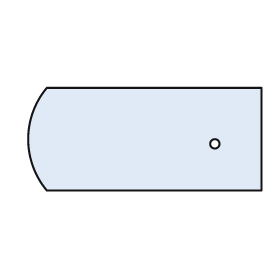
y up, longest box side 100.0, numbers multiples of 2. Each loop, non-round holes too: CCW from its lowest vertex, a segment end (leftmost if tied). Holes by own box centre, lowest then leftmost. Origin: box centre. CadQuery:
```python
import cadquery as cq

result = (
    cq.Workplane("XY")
    .moveTo(-42.0, -22.0)
    .lineTo(50.0, -22.0)
    .lineTo(50.0, 22.0)
    .lineTo(-42.0, 22.0)
    .threePointArc((-50.0, 0.0), (-42.0, -22.0))
    .close()
    .moveTo(30.0, -2.0)
    .circle(2.0)
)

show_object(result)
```